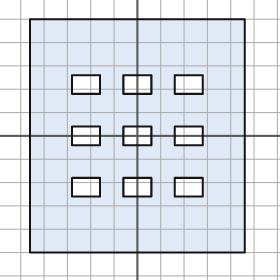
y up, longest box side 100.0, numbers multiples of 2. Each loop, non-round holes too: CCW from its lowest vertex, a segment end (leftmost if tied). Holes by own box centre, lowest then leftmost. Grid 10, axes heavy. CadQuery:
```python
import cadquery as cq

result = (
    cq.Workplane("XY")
    .moveTo(-46.0, -50.0)
    .lineTo(46.0, -50.0)
    .lineTo(46.0, 50.0)
    .lineTo(-46.0, 50.0)
    .close()
    .moveTo(-28.0, -26.0)
    .lineTo(-16.0, -26.0)
    .lineTo(-16.0, -18.0)
    .lineTo(-28.0, -18.0)
    .close()
    .moveTo(-6.0, -26.0)
    .lineTo(6.0, -26.0)
    .lineTo(6.0, -18.0)
    .lineTo(-6.0, -18.0)
    .close()
    .moveTo(16.0, -26.0)
    .lineTo(28.0, -26.0)
    .lineTo(28.0, -18.0)
    .lineTo(16.0, -18.0)
    .close()
    .moveTo(-28.0, -4.0)
    .lineTo(-16.0, -4.0)
    .lineTo(-16.0, 4.0)
    .lineTo(-28.0, 4.0)
    .close()
    .moveTo(-6.0, -4.0)
    .lineTo(6.0, -4.0)
    .lineTo(6.0, 4.0)
    .lineTo(-6.0, 4.0)
    .close()
    .moveTo(16.0, -4.0)
    .lineTo(28.0, -4.0)
    .lineTo(28.0, 4.0)
    .lineTo(16.0, 4.0)
    .close()
    .moveTo(-28.0, 18.0)
    .lineTo(-16.0, 18.0)
    .lineTo(-16.0, 26.0)
    .lineTo(-28.0, 26.0)
    .close()
    .moveTo(-6.0, 18.0)
    .lineTo(6.0, 18.0)
    .lineTo(6.0, 26.0)
    .lineTo(-6.0, 26.0)
    .close()
    .moveTo(16.0, 18.0)
    .lineTo(28.0, 18.0)
    .lineTo(28.0, 26.0)
    .lineTo(16.0, 26.0)
    .close()
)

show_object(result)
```